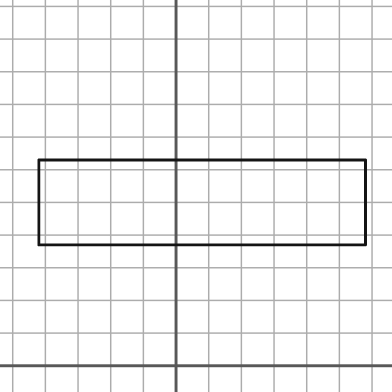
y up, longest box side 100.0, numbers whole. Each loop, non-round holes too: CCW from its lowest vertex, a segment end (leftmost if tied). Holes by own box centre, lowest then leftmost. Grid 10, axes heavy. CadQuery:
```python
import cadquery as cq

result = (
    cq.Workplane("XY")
    .moveTo(-42.0, 37.0)
    .lineTo(58.0, 37.0)
    .lineTo(58.0, 63.0)
    .lineTo(-42.0, 63.0)
    .close()
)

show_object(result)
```